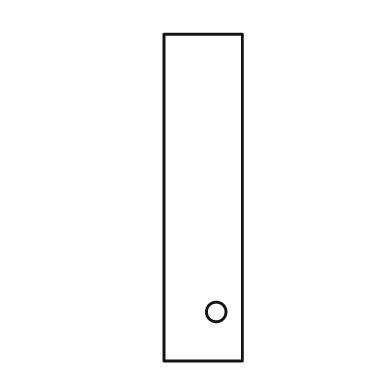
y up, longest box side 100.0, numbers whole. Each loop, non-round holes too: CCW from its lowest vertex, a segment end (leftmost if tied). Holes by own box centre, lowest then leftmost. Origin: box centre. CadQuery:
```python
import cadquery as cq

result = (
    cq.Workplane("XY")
    .moveTo(-12.0, -50.0)
    .lineTo(12.0, -50.0)
    .lineTo(12.0, 50.0)
    .lineTo(-12.0, 50.0)
    .close()
    .moveTo(4.0, -35.0)
    .circle(3.0)
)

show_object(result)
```